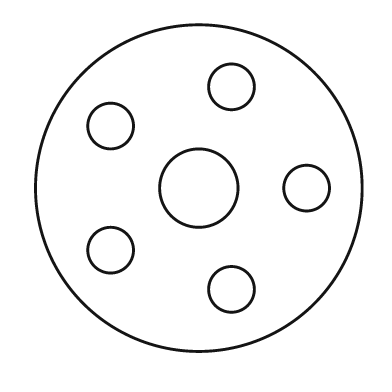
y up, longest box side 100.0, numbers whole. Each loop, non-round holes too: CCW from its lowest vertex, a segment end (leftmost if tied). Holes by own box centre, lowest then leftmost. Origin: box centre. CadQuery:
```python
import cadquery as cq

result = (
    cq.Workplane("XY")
    .moveTo(0.0, 0.0)
    .circle(50.0)
    .moveTo(10.0, -31.0)
    .circle(7.0)
    .moveTo(-27.0, -19.0)
    .circle(7.0)
    .moveTo(0.0, 0.0)
    .circle(12.0)
    .moveTo(33.0, 0.0)
    .circle(7.0)
    .moveTo(-27.0, 19.0)
    .circle(7.0)
    .moveTo(10.0, 31.0)
    .circle(7.0)
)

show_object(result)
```